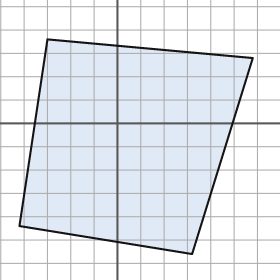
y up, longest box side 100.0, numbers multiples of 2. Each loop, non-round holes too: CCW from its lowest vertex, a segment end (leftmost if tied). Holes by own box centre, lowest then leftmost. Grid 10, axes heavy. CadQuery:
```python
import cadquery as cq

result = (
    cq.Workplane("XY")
    .moveTo(32.0, -56.0)
    .lineTo(58.0, 28.0)
    .lineTo(-30.0, 36.0)
    .lineTo(-42.0, -44.0)
    .close()
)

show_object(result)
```